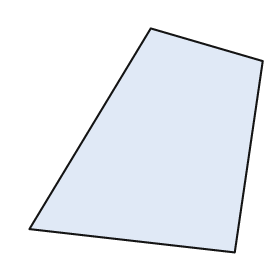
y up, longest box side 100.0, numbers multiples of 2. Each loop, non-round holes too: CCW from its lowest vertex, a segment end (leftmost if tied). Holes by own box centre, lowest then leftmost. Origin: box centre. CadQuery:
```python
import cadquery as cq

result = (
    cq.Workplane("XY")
    .moveTo(38.0, -48.0)
    .lineTo(50.0, 34.0)
    .lineTo(2.0, 48.0)
    .lineTo(-50.0, -38.0)
    .close()
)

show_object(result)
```